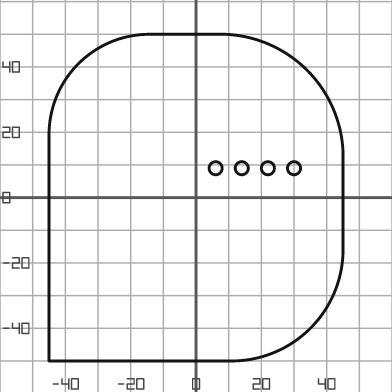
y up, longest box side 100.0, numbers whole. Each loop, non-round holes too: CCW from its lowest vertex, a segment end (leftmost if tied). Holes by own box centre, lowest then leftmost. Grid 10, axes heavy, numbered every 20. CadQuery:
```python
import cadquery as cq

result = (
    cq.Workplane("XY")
    .moveTo(-45.0, -50.0)
    .lineTo(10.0, -50.0)
    .threePointArc((35.0, -40.0), (45.0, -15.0))
    .lineTo(45.0, 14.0)
    .threePointArc((34.0, 39.0), (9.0, 50.0))
    .lineTo(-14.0, 50.0)
    .threePointArc((-36.0, 41.0), (-45.0, 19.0))
    .close()
    .moveTo(6.0, 9.0)
    .circle(2.0)
    .moveTo(14.0, 9.0)
    .circle(2.0)
    .moveTo(22.0, 9.0)
    .circle(2.0)
    .moveTo(30.0, 9.0)
    .circle(2.0)
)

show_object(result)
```